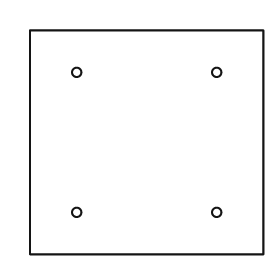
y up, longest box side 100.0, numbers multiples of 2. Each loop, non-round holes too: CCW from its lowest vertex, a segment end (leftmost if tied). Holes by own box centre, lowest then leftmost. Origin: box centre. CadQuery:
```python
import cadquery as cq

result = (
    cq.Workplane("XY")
    .moveTo(-50.0, -48.0)
    .lineTo(50.0, -48.0)
    .lineTo(50.0, 48.0)
    .lineTo(-50.0, 48.0)
    .close()
    .moveTo(-30.0, -30.0)
    .circle(2.0)
    .moveTo(30.0, -30.0)
    .circle(2.0)
    .moveTo(-30.0, 30.0)
    .circle(2.0)
    .moveTo(30.0, 30.0)
    .circle(2.0)
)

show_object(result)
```